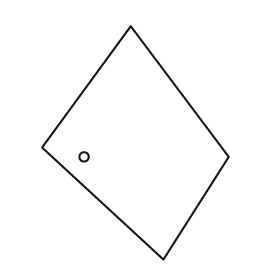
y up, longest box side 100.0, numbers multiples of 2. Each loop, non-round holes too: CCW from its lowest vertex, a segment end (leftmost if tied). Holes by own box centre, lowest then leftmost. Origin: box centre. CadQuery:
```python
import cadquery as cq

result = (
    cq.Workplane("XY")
    .moveTo(12.0, -50.0)
    .lineTo(40.0, -6.0)
    .lineTo(-2.0, 50.0)
    .lineTo(-40.0, -2.0)
    .close()
    .moveTo(-22.0, -6.0)
    .circle(2.0)
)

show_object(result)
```